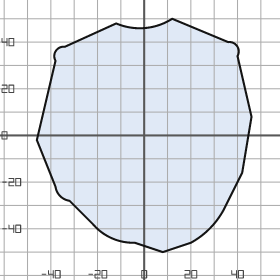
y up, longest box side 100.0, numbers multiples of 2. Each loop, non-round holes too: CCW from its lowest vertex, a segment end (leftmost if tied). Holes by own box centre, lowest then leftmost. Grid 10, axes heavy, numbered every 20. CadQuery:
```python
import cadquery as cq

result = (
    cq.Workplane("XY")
    .moveTo(8.0, -50.0)
    .lineTo(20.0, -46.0)
    .threePointArc((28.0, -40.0), (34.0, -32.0))
    .lineTo(42.0, -16.0)
    .lineTo(46.0, 8.0)
    .lineTo(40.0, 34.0)
    .threePointArc((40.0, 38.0), (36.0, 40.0))
    .lineTo(12.0, 50.0)
    .threePointArc((0.0, 46.0), (-12.0, 48.0))
    .lineTo(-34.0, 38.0)
    .threePointArc((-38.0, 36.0), (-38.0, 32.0))
    .lineTo(-46.0, -2.0)
    .lineTo(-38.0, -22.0)
    .threePointArc((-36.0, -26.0), (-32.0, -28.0))
    .lineTo(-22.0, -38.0)
    .threePointArc((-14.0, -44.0), (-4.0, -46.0))
    .close()
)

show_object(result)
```